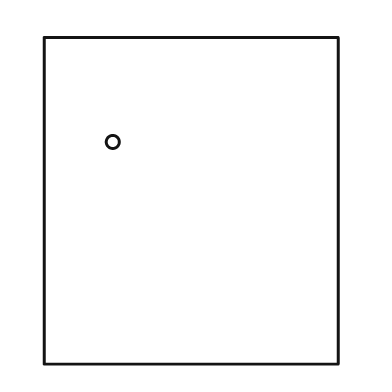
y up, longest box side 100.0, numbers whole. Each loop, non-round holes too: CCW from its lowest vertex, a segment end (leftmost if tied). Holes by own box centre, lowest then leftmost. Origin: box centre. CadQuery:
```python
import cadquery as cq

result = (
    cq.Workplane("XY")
    .moveTo(-45.0, -50.0)
    .lineTo(45.0, -50.0)
    .lineTo(45.0, 50.0)
    .lineTo(-45.0, 50.0)
    .close()
    .moveTo(-24.0, 18.0)
    .circle(2.0)
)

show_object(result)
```